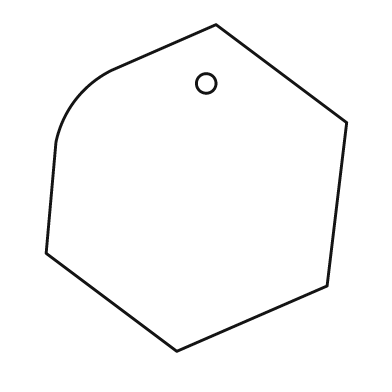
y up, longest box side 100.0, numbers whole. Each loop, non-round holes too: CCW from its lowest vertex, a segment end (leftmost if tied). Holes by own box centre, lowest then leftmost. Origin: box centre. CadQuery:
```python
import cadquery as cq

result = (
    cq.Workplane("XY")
    .moveTo(-6.0, -50.0)
    .lineTo(40.0, -30.0)
    .lineTo(46.0, 20.0)
    .lineTo(6.0, 50.0)
    .lineTo(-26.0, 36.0)
    .threePointArc((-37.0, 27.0), (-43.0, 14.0))
    .lineTo(-46.0, -20.0)
    .close()
    .moveTo(3.0, 32.0)
    .circle(3.0)
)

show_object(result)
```